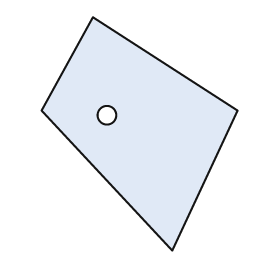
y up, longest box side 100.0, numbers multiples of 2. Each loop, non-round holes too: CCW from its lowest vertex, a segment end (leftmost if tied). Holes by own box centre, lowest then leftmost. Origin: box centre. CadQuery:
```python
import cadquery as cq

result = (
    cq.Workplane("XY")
    .moveTo(14.0, -50.0)
    .lineTo(42.0, 10.0)
    .lineTo(-20.0, 50.0)
    .lineTo(-42.0, 10.0)
    .close()
    .moveTo(-14.0, 8.0)
    .circle(4.0)
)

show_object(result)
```